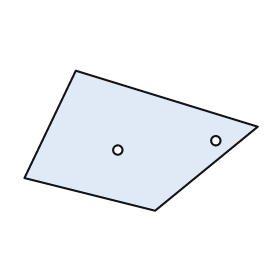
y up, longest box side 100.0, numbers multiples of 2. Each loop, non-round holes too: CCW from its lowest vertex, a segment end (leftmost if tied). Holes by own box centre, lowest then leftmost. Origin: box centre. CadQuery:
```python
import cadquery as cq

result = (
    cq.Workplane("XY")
    .moveTo(6.0, -30.0)
    .lineTo(50.0, 6.0)
    .lineTo(-28.0, 30.0)
    .lineTo(-50.0, -16.0)
    .close()
    .moveTo(-10.0, -4.0)
    .circle(2.0)
    .moveTo(32.0, 0.0)
    .circle(2.0)
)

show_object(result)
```